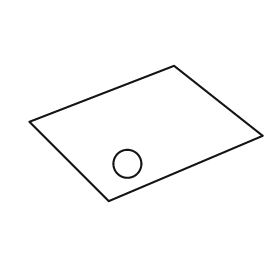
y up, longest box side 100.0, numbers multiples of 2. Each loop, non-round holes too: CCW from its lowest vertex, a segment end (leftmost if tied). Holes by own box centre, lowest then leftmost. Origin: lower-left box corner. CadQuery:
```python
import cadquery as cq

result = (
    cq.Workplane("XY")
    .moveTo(34.0, 0.0)
    .lineTo(100.0, 28.0)
    .lineTo(62.0, 58.0)
    .lineTo(0.0, 34.0)
    .close()
    .moveTo(42.0, 16.0)
    .circle(6.0)
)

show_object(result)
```